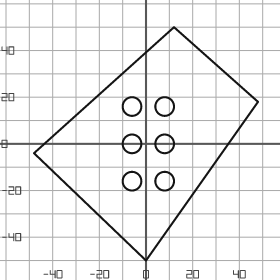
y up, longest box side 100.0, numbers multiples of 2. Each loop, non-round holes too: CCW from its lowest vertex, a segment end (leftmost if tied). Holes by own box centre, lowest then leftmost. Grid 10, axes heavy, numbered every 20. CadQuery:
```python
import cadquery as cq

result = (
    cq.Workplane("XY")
    .moveTo(0.0, -50.0)
    .lineTo(48.0, 18.0)
    .lineTo(12.0, 50.0)
    .lineTo(-48.0, -4.0)
    .close()
    .moveTo(-6.0, -16.0)
    .circle(4.0)
    .moveTo(8.0, -16.0)
    .circle(4.0)
    .moveTo(-6.0, 0.0)
    .circle(4.0)
    .moveTo(8.0, 0.0)
    .circle(4.0)
    .moveTo(-6.0, 16.0)
    .circle(4.0)
    .moveTo(8.0, 16.0)
    .circle(4.0)
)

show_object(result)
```